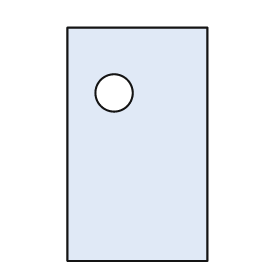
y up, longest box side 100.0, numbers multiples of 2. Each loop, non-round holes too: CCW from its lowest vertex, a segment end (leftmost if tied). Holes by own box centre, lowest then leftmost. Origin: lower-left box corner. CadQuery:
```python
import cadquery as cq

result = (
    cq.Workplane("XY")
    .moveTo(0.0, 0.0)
    .lineTo(60.0, 0.0)
    .lineTo(60.0, 100.0)
    .lineTo(0.0, 100.0)
    .close()
    .moveTo(20.0, 72.0)
    .circle(8.0)
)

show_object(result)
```